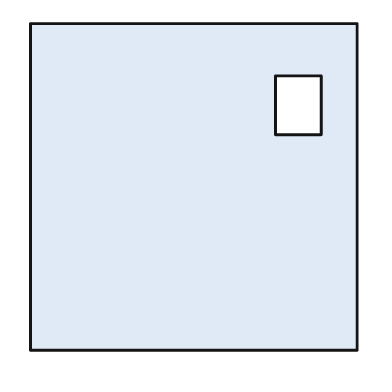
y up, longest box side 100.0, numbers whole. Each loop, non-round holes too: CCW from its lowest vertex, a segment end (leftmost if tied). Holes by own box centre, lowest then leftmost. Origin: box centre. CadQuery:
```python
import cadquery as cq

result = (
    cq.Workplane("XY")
    .moveTo(-50.0, -50.0)
    .lineTo(50.0, -50.0)
    .lineTo(50.0, 50.0)
    .lineTo(-50.0, 50.0)
    .close()
    .moveTo(25.0, 16.0)
    .lineTo(39.0, 16.0)
    .lineTo(39.0, 34.0)
    .lineTo(25.0, 34.0)
    .close()
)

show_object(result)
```